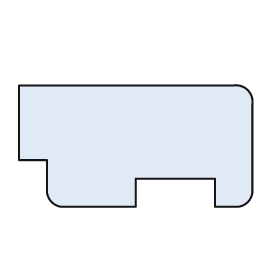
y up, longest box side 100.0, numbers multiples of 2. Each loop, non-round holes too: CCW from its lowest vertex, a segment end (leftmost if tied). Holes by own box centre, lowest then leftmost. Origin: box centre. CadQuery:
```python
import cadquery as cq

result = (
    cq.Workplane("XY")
    .moveTo(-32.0, -26.0)
    .lineTo(0.0, -26.0)
    .lineTo(0.0, -14.0)
    .lineTo(34.0, -14.0)
    .lineTo(34.0, -26.0)
    .lineTo(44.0, -26.0)
    .threePointArc((48.0, -24.0), (50.0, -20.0))
    .lineTo(50.0, 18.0)
    .threePointArc((48.0, 24.0), (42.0, 26.0))
    .lineTo(-50.0, 26.0)
    .lineTo(-50.0, -6.0)
    .lineTo(-38.0, -6.0)
    .lineTo(-38.0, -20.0)
    .threePointArc((-36.0, -24.0), (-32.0, -26.0))
    .close()
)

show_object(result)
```